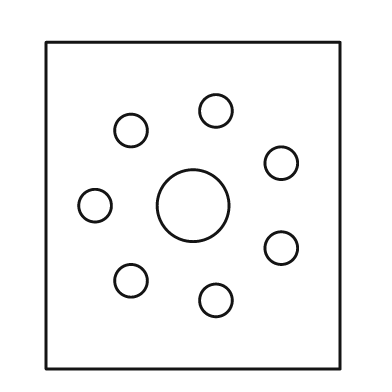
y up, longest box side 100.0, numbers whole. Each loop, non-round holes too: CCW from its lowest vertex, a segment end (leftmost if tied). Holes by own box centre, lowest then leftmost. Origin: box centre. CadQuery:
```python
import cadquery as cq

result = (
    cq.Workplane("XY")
    .moveTo(-45.0, -50.0)
    .lineTo(45.0, -50.0)
    .lineTo(45.0, 50.0)
    .lineTo(-45.0, 50.0)
    .close()
    .moveTo(7.0, -29.0)
    .circle(5.0)
    .moveTo(-19.0, -23.0)
    .circle(5.0)
    .moveTo(27.0, -13.0)
    .circle(5.0)
    .moveTo(-30.0, 0.0)
    .circle(5.0)
    .moveTo(0.0, 0.0)
    .circle(11.0)
    .moveTo(27.0, 13.0)
    .circle(5.0)
    .moveTo(-19.0, 23.0)
    .circle(5.0)
    .moveTo(7.0, 29.0)
    .circle(5.0)
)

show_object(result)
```